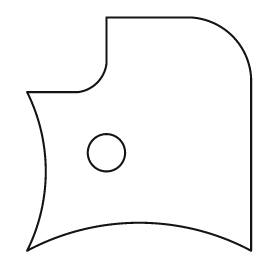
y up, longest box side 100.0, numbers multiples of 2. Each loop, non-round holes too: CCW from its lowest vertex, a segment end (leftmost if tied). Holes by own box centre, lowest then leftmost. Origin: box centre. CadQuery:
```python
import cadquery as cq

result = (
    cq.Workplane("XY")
    .moveTo(-48.0, -50.0)
    .threePointArc((0.0, -38.0), (48.0, -50.0))
    .lineTo(48.0, 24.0)
    .threePointArc((40.0, 42.0), (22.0, 50.0))
    .lineTo(-14.0, 50.0)
    .lineTo(-14.0, 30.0)
    .threePointArc((-18.0, 22.0), (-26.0, 18.0))
    .lineTo(-48.0, 18.0)
    .threePointArc((-40.0, -16.0), (-48.0, -50.0))
    .close()
    .moveTo(-14.0, -8.0)
    .circle(8.0)
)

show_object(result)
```